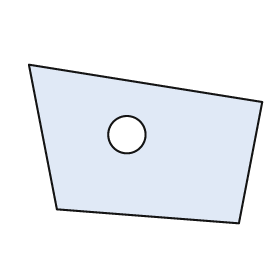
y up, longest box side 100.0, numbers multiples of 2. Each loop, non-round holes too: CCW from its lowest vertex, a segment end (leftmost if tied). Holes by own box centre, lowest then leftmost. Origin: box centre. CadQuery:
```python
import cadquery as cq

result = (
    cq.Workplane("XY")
    .moveTo(40.0, -34.0)
    .lineTo(50.0, 18.0)
    .lineTo(-50.0, 34.0)
    .lineTo(-38.0, -28.0)
    .close()
    .moveTo(-8.0, 4.0)
    .circle(8.0)
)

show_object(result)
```